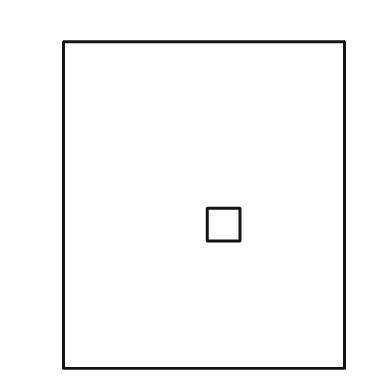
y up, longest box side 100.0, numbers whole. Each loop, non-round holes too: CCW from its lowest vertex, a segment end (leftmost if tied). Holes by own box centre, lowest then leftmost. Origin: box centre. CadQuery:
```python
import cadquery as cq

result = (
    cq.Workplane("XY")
    .moveTo(-43.0, -50.0)
    .lineTo(43.0, -50.0)
    .lineTo(43.0, 50.0)
    .lineTo(-43.0, 50.0)
    .close()
    .moveTo(1.0, -11.0)
    .lineTo(11.0, -11.0)
    .lineTo(11.0, -1.0)
    .lineTo(1.0, -1.0)
    .close()
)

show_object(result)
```